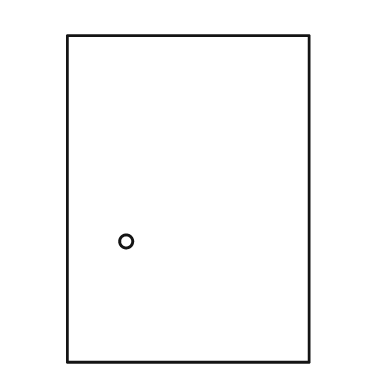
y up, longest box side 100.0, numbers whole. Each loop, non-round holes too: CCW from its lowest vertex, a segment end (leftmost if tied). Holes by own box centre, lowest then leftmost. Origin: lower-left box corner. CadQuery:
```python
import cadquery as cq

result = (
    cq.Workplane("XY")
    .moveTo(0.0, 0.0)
    .lineTo(74.0, 0.0)
    .lineTo(74.0, 100.0)
    .lineTo(0.0, 100.0)
    .close()
    .moveTo(18.0, 37.0)
    .circle(2.0)
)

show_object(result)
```